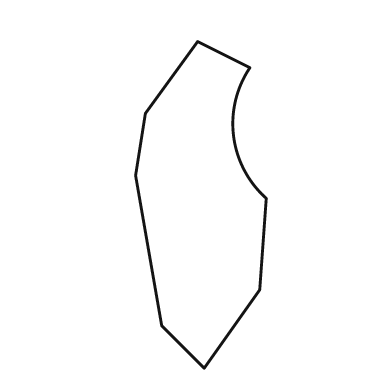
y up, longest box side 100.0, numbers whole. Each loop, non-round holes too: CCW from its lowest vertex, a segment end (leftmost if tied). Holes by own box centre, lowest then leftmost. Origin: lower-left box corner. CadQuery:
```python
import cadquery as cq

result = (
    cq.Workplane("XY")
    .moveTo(21.0, 0.0)
    .lineTo(38.0, 24.0)
    .lineTo(40.0, 52.0)
    .threePointArc((30.0, 71.0), (35.0, 92.0))
    .lineTo(19.0, 100.0)
    .lineTo(3.0, 78.0)
    .lineTo(0.0, 59.0)
    .lineTo(8.0, 13.0)
    .close()
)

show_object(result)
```